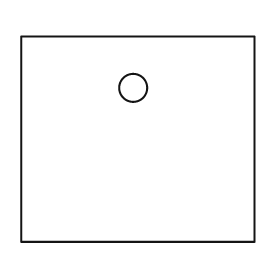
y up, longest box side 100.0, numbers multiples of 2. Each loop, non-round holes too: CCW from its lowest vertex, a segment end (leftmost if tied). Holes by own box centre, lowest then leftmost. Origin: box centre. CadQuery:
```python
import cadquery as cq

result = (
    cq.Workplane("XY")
    .moveTo(-50.0, -44.0)
    .lineTo(50.0, -44.0)
    .lineTo(50.0, 44.0)
    .lineTo(-50.0, 44.0)
    .close()
    .moveTo(-2.0, 22.0)
    .circle(6.0)
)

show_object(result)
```